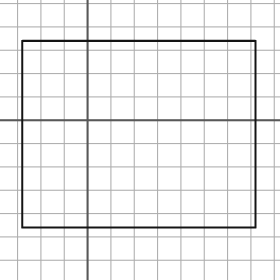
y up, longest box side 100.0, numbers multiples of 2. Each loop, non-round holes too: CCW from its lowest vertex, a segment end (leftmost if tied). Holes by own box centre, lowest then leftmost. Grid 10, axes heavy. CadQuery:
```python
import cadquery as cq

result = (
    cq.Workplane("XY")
    .moveTo(-28.0, -46.0)
    .lineTo(72.0, -46.0)
    .lineTo(72.0, 34.0)
    .lineTo(-28.0, 34.0)
    .close()
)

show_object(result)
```